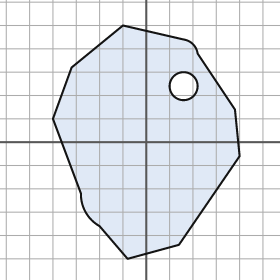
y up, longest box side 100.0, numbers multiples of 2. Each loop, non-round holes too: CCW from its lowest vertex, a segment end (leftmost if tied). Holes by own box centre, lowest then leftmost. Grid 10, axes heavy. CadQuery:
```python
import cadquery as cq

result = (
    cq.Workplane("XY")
    .moveTo(-8.0, -50.0)
    .lineTo(14.0, -44.0)
    .lineTo(40.0, -6.0)
    .lineTo(38.0, 14.0)
    .lineTo(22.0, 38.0)
    .threePointArc((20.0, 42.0), (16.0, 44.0))
    .lineTo(-10.0, 50.0)
    .lineTo(-32.0, 32.0)
    .lineTo(-40.0, 10.0)
    .lineTo(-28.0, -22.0)
    .threePointArc((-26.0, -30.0), (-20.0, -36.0))
    .close()
    .moveTo(16.0, 24.0)
    .circle(6.0)
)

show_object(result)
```